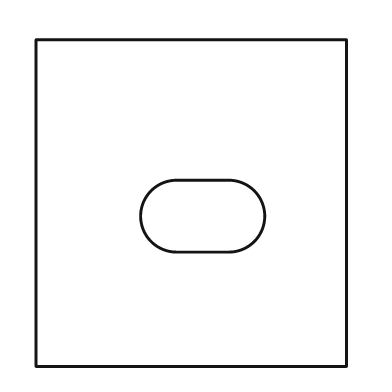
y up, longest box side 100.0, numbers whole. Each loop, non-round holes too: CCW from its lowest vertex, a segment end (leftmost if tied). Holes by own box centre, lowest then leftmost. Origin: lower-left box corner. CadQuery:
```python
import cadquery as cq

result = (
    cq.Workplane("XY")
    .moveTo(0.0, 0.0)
    .lineTo(95.0, 0.0)
    .lineTo(95.0, 100.0)
    .lineTo(0.0, 100.0)
    .close()
    .moveTo(43.0, 35.0)
    .lineTo(59.0, 35.0)
    .threePointArc((70.0, 46.0), (59.0, 57.0))
    .lineTo(43.0, 57.0)
    .threePointArc((32.0, 46.0), (43.0, 35.0))
    .close()
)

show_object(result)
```